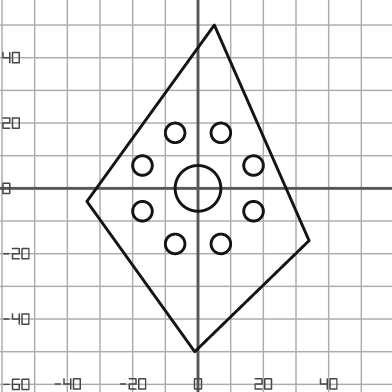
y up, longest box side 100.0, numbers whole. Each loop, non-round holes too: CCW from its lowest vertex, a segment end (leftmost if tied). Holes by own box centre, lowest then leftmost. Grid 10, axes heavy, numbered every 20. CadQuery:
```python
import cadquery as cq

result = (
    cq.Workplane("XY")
    .moveTo(-1.0, -50.0)
    .lineTo(34.0, -16.0)
    .lineTo(5.0, 50.0)
    .lineTo(-34.0, -4.0)
    .close()
    .moveTo(-7.0, -17.0)
    .circle(3.0)
    .moveTo(7.0, -17.0)
    .circle(3.0)
    .moveTo(-17.0, -7.0)
    .circle(3.0)
    .moveTo(17.0, -7.0)
    .circle(3.0)
    .moveTo(0.0, 0.0)
    .circle(7.0)
    .moveTo(-17.0, 7.0)
    .circle(3.0)
    .moveTo(17.0, 7.0)
    .circle(3.0)
    .moveTo(-7.0, 17.0)
    .circle(3.0)
    .moveTo(7.0, 17.0)
    .circle(3.0)
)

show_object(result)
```